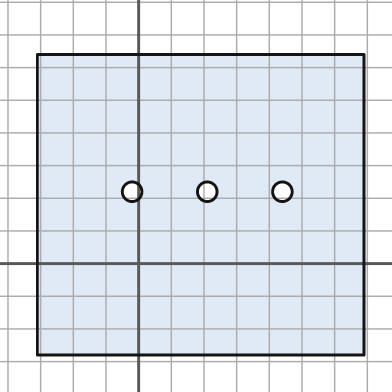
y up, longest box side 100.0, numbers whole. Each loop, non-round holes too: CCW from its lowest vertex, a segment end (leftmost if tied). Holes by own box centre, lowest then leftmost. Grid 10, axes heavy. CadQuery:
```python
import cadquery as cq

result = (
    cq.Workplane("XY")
    .moveTo(-31.0, -28.0)
    .lineTo(69.0, -28.0)
    .lineTo(69.0, 64.0)
    .lineTo(-31.0, 64.0)
    .close()
    .moveTo(-2.0, 22.0)
    .circle(3.0)
    .moveTo(21.0, 22.0)
    .circle(3.0)
    .moveTo(44.0, 22.0)
    .circle(3.0)
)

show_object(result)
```